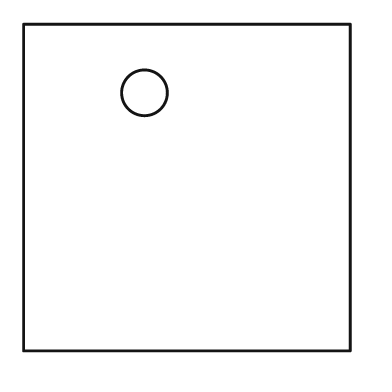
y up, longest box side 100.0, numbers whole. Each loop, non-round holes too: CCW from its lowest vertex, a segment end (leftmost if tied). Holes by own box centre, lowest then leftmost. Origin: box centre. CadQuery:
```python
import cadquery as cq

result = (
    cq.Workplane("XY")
    .moveTo(-50.0, -50.0)
    .lineTo(50.0, -50.0)
    .lineTo(50.0, 50.0)
    .lineTo(-50.0, 50.0)
    .close()
    .moveTo(-13.0, 29.0)
    .circle(7.0)
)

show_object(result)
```